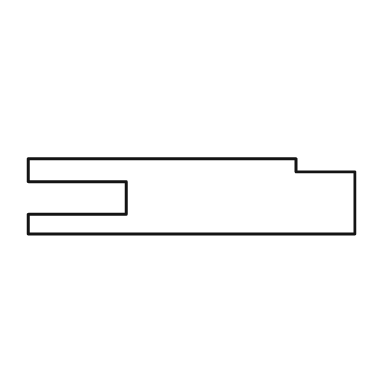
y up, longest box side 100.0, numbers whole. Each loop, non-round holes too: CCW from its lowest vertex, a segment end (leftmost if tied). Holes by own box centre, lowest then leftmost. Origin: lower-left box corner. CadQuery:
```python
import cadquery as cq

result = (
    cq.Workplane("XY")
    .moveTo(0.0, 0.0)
    .lineTo(100.0, 0.0)
    .lineTo(100.0, 19.0)
    .lineTo(82.0, 19.0)
    .lineTo(82.0, 23.0)
    .lineTo(0.0, 23.0)
    .lineTo(0.0, 16.0)
    .lineTo(30.0, 16.0)
    .lineTo(30.0, 6.0)
    .lineTo(0.0, 6.0)
    .close()
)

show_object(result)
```